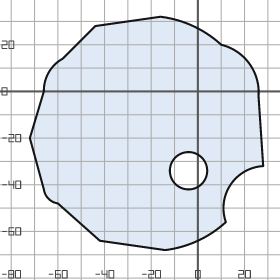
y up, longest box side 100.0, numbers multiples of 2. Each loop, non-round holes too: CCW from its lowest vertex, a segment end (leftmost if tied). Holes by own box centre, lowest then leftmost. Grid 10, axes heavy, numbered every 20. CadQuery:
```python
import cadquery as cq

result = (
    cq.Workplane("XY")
    .moveTo(-14.0, -68.0)
    .threePointArc((0.0, -64.0), (12.0, -56.0))
    .threePointArc((14.0, -40.0), (28.0, -32.0))
    .lineTo(26.0, -2.0)
    .threePointArc((22.0, 12.0), (10.0, 20.0))
    .threePointArc((-2.0, 28.0), (-16.0, 32.0))
    .lineTo(-44.0, 28.0)
    .lineTo(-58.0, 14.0)
    .threePointArc((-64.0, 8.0), (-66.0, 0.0))
    .lineTo(-72.0, -20.0)
    .lineTo(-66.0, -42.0)
    .threePointArc((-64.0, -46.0), (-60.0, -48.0))
    .lineTo(-42.0, -64.0)
    .close()
    .moveTo(-4.0, -34.0)
    .circle(8.0)
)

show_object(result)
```